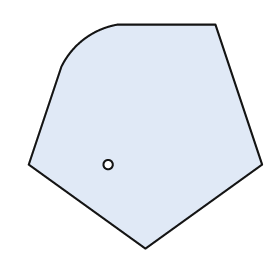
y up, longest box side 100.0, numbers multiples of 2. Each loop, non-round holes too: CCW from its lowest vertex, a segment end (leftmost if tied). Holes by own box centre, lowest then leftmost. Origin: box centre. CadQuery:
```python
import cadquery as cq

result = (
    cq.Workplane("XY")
    .moveTo(0.0, -48.0)
    .lineTo(50.0, -12.0)
    .lineTo(30.0, 48.0)
    .lineTo(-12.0, 48.0)
    .threePointArc((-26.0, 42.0), (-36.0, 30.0))
    .lineTo(-50.0, -12.0)
    .close()
    .moveTo(-16.0, -12.0)
    .circle(2.0)
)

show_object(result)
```